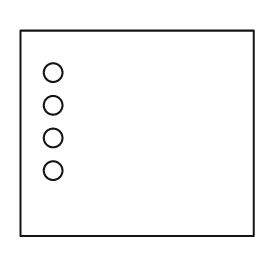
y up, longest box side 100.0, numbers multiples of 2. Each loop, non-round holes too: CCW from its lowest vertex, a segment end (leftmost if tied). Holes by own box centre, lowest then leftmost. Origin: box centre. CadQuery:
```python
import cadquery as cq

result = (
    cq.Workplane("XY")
    .moveTo(-50.0, -44.0)
    .lineTo(50.0, -44.0)
    .lineTo(50.0, 44.0)
    .lineTo(-50.0, 44.0)
    .close()
    .moveTo(-36.0, -16.0)
    .circle(4.0)
    .moveTo(-36.0, -2.0)
    .circle(4.0)
    .moveTo(-36.0, 12.0)
    .circle(4.0)
    .moveTo(-36.0, 26.0)
    .circle(4.0)
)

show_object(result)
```